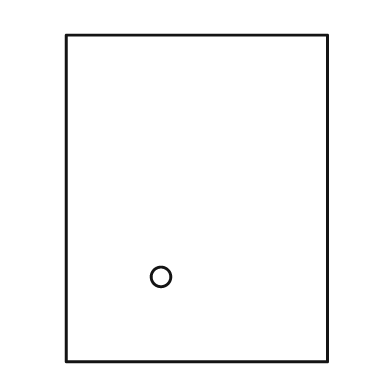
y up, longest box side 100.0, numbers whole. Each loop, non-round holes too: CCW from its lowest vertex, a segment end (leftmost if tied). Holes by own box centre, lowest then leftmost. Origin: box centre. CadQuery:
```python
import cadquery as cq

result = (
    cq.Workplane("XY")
    .moveTo(-40.0, -50.0)
    .lineTo(40.0, -50.0)
    .lineTo(40.0, 50.0)
    .lineTo(-40.0, 50.0)
    .close()
    .moveTo(-11.0, -24.0)
    .circle(3.0)
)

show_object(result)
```